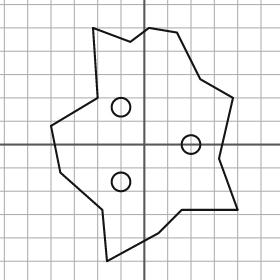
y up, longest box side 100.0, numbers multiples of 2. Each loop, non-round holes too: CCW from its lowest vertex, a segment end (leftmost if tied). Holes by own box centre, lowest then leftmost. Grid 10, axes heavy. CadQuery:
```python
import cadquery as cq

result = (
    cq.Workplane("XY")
    .moveTo(-16.0, -50.0)
    .lineTo(6.0, -38.0)
    .lineTo(16.0, -28.0)
    .lineTo(40.0, -28.0)
    .lineTo(32.0, -6.0)
    .lineTo(38.0, 20.0)
    .lineTo(24.0, 28.0)
    .lineTo(14.0, 48.0)
    .lineTo(2.0, 50.0)
    .lineTo(-6.0, 44.0)
    .lineTo(-22.0, 50.0)
    .lineTo(-20.0, 20.0)
    .lineTo(-40.0, 8.0)
    .lineTo(-36.0, -12.0)
    .lineTo(-18.0, -28.0)
    .close()
    .moveTo(-10.0, -16.0)
    .circle(4.0)
    .moveTo(20.0, 0.0)
    .circle(4.0)
    .moveTo(-10.0, 16.0)
    .circle(4.0)
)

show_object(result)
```